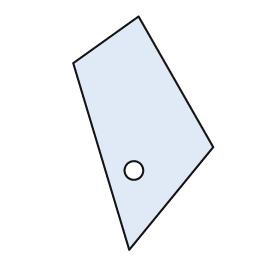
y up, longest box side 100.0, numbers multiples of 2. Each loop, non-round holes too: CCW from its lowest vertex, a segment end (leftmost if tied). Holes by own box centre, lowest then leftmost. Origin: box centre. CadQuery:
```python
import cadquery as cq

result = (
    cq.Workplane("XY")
    .moveTo(-6.0, -50.0)
    .lineTo(30.0, -6.0)
    .lineTo(-2.0, 50.0)
    .lineTo(-30.0, 30.0)
    .close()
    .moveTo(-4.0, -16.0)
    .circle(4.0)
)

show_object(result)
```